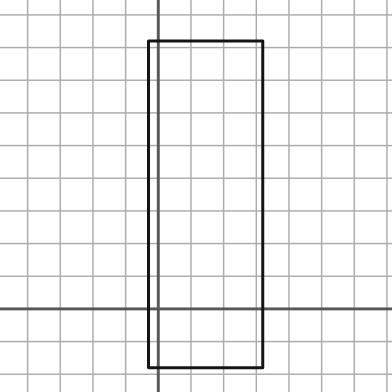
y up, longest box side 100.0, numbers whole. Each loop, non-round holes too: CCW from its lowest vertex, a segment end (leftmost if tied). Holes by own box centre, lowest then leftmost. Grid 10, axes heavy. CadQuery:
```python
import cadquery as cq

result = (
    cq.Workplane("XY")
    .moveTo(-3.0, -18.0)
    .lineTo(32.0, -18.0)
    .lineTo(32.0, 82.0)
    .lineTo(-3.0, 82.0)
    .close()
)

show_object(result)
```